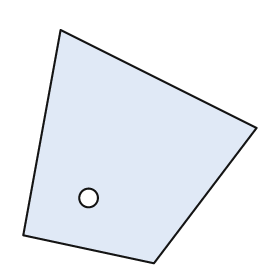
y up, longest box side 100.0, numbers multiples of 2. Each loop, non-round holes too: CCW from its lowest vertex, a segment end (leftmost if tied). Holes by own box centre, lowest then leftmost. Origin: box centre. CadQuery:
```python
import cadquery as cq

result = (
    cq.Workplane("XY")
    .moveTo(6.0, -50.0)
    .lineTo(50.0, 8.0)
    .lineTo(-34.0, 50.0)
    .lineTo(-50.0, -38.0)
    .close()
    .moveTo(-22.0, -22.0)
    .circle(4.0)
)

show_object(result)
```